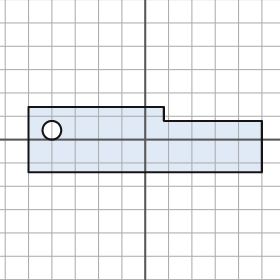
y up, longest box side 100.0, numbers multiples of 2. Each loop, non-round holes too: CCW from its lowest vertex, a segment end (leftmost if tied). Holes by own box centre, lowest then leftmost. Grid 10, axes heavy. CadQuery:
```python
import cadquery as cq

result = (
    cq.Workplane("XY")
    .moveTo(-50.0, -14.0)
    .lineTo(50.0, -14.0)
    .lineTo(50.0, 8.0)
    .lineTo(8.0, 8.0)
    .lineTo(8.0, 14.0)
    .lineTo(-50.0, 14.0)
    .close()
    .moveTo(-40.0, 4.0)
    .circle(4.0)
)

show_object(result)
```